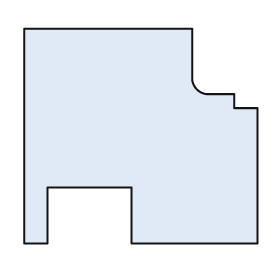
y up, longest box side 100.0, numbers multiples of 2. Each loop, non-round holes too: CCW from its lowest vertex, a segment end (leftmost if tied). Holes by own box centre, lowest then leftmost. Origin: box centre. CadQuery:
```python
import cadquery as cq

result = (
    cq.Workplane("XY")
    .moveTo(-50.0, -46.0)
    .lineTo(-40.0, -46.0)
    .lineTo(-40.0, -22.0)
    .lineTo(-4.0, -22.0)
    .lineTo(-4.0, -46.0)
    .lineTo(50.0, -46.0)
    .lineTo(50.0, 12.0)
    .lineTo(40.0, 12.0)
    .lineTo(40.0, 18.0)
    .lineTo(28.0, 18.0)
    .threePointArc((24.0, 20.0), (22.0, 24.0))
    .lineTo(22.0, 46.0)
    .lineTo(-50.0, 46.0)
    .close()
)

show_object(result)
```